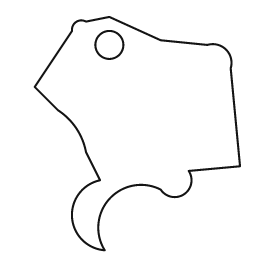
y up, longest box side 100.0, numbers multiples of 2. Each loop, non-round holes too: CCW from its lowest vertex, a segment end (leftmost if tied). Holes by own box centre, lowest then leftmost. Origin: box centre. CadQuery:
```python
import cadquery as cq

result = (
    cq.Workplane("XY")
    .moveTo(-14.0, -50.0)
    .threePointArc((-12.0, -28.0), (10.0, -24.0))
    .threePointArc((20.0, -26.0), (22.0, -16.0))
    .lineTo(44.0, -14.0)
    .lineTo(40.0, 28.0)
    .threePointArc((38.0, 36.0), (30.0, 38.0))
    .lineTo(10.0, 40.0)
    .lineTo(-12.0, 50.0)
    .lineTo(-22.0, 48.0)
    .threePointArc((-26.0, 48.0), (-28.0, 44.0))
    .lineTo(-44.0, 20.0)
    .lineTo(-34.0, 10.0)
    .threePointArc((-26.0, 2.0), (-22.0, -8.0))
    .lineTo(-16.0, -20.0)
    .threePointArc((-28.0, -36.0), (-14.0, -50.0))
    .close()
    .moveTo(-12.0, 38.0)
    .circle(6.0)
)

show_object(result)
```